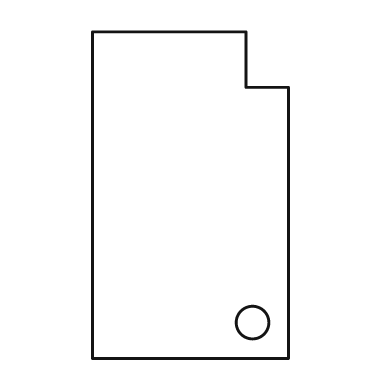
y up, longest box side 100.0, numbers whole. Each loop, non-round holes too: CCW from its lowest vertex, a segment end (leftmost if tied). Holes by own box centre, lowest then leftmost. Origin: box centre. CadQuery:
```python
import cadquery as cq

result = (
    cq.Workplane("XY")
    .moveTo(-30.0, -50.0)
    .lineTo(30.0, -50.0)
    .lineTo(30.0, 33.0)
    .lineTo(17.0, 33.0)
    .lineTo(17.0, 50.0)
    .lineTo(-30.0, 50.0)
    .close()
    .moveTo(19.0, -39.0)
    .circle(5.0)
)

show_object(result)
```